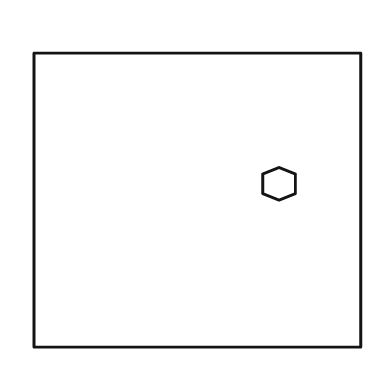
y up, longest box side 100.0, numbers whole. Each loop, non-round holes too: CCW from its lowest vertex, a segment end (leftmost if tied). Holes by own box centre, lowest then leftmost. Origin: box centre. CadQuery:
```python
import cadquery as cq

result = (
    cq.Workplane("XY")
    .moveTo(-50.0, -45.0)
    .lineTo(50.0, -45.0)
    .lineTo(50.0, 45.0)
    .lineTo(-50.0, 45.0)
    .close()
    .moveTo(25.0, 0.0)
    .lineTo(30.0, 2.0)
    .lineTo(30.0, 8.0)
    .lineTo(25.0, 10.0)
    .lineTo(20.0, 8.0)
    .lineTo(20.0, 2.0)
    .close()
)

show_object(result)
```